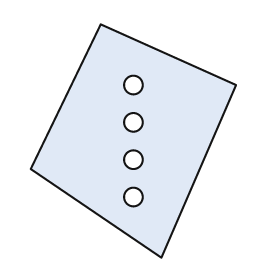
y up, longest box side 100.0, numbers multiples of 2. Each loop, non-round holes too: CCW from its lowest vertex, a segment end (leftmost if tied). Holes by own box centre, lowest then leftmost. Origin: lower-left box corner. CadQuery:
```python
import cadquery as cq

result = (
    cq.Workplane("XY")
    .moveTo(56.0, 0.0)
    .lineTo(88.0, 74.0)
    .lineTo(30.0, 100.0)
    .lineTo(0.0, 38.0)
    .close()
    .moveTo(44.0, 26.0)
    .circle(4.0)
    .moveTo(44.0, 42.0)
    .circle(4.0)
    .moveTo(44.0, 58.0)
    .circle(4.0)
    .moveTo(44.0, 74.0)
    .circle(4.0)
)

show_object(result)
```